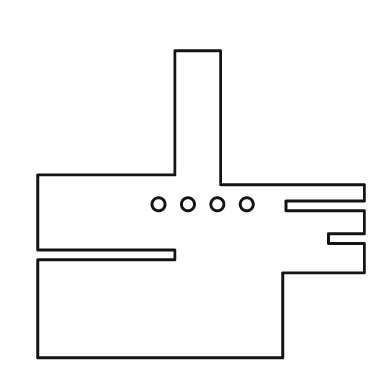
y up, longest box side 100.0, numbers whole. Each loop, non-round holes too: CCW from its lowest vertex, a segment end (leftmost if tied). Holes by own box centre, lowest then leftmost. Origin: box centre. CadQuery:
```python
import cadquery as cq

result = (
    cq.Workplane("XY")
    .moveTo(-50.0, -47.0)
    .lineTo(25.0, -47.0)
    .lineTo(25.0, -21.0)
    .lineTo(50.0, -21.0)
    .lineTo(50.0, -12.0)
    .lineTo(39.0, -12.0)
    .lineTo(39.0, -9.0)
    .lineTo(50.0, -9.0)
    .lineTo(50.0, -2.0)
    .lineTo(26.0, -2.0)
    .lineTo(26.0, 1.0)
    .lineTo(50.0, 1.0)
    .lineTo(50.0, 6.0)
    .lineTo(6.0, 6.0)
    .lineTo(6.0, 47.0)
    .lineTo(-8.0, 47.0)
    .lineTo(-8.0, 9.0)
    .lineTo(-50.0, 9.0)
    .lineTo(-50.0, -14.0)
    .lineTo(-8.0, -14.0)
    .lineTo(-8.0, -17.0)
    .lineTo(-50.0, -17.0)
    .close()
    .moveTo(-13.0, 0.0)
    .circle(2.0)
    .moveTo(-4.0, 0.0)
    .circle(2.0)
    .moveTo(5.0, 0.0)
    .circle(2.0)
    .moveTo(14.0, 0.0)
    .circle(2.0)
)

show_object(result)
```